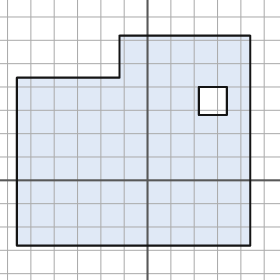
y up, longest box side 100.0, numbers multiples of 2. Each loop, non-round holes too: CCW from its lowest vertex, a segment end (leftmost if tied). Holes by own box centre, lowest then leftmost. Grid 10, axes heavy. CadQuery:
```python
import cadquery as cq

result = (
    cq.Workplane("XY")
    .moveTo(-56.0, -28.0)
    .lineTo(44.0, -28.0)
    .lineTo(44.0, 62.0)
    .lineTo(-12.0, 62.0)
    .lineTo(-12.0, 44.0)
    .lineTo(-56.0, 44.0)
    .close()
    .moveTo(22.0, 28.0)
    .lineTo(34.0, 28.0)
    .lineTo(34.0, 40.0)
    .lineTo(22.0, 40.0)
    .close()
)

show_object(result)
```